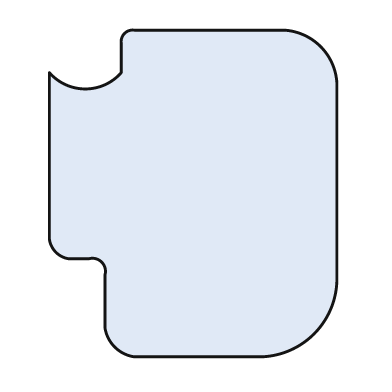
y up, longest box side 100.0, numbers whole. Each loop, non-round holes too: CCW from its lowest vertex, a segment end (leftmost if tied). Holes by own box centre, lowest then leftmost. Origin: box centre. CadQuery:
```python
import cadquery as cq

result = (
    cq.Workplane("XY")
    .moveTo(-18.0, -50.0)
    .lineTo(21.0, -50.0)
    .threePointArc((37.0, -43.0), (44.0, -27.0))
    .lineTo(44.0, 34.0)
    .threePointArc((39.0, 45.0), (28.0, 50.0))
    .lineTo(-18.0, 50.0)
    .threePointArc((-21.0, 49.0), (-22.0, 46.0))
    .lineTo(-22.0, 37.0)
    .threePointArc((-33.0, 32.0), (-44.0, 37.0))
    .lineTo(-44.0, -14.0)
    .threePointArc((-42.0, -18.0), (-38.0, -20.0))
    .lineTo(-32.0, -20.0)
    .threePointArc((-28.0, -21.0), (-27.0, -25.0))
    .lineTo(-27.0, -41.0)
    .threePointArc((-24.0, -47.0), (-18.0, -50.0))
    .close()
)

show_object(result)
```